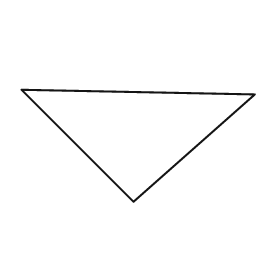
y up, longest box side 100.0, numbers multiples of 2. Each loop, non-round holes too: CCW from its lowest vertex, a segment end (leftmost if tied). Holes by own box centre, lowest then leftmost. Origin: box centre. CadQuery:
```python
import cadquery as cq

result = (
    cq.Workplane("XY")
    .moveTo(-2.0, -24.0)
    .lineTo(50.0, 22.0)
    .lineTo(-50.0, 24.0)
    .close()
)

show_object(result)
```